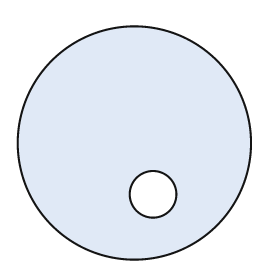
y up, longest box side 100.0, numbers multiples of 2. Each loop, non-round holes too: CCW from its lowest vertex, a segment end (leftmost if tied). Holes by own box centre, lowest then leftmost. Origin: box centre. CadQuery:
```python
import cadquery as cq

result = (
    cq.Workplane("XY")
    .moveTo(0.0, 0.0)
    .circle(50.0)
    .moveTo(8.0, -22.0)
    .circle(10.0)
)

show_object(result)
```